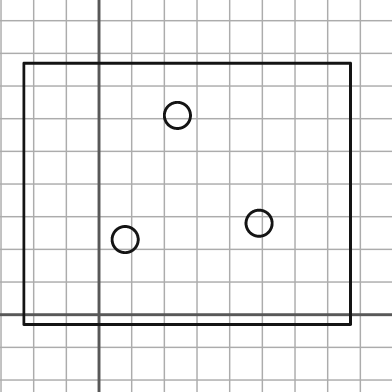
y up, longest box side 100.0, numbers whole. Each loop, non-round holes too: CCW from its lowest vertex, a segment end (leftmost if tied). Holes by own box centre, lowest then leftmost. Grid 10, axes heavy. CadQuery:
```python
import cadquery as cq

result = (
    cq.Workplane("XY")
    .moveTo(-23.0, -3.0)
    .lineTo(77.0, -3.0)
    .lineTo(77.0, 77.0)
    .lineTo(-23.0, 77.0)
    .close()
    .moveTo(8.0, 23.0)
    .circle(4.0)
    .moveTo(49.0, 28.0)
    .circle(4.0)
    .moveTo(24.0, 61.0)
    .circle(4.0)
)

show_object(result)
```